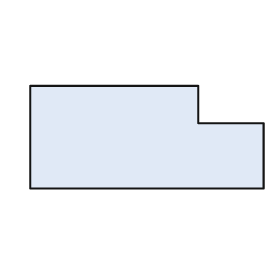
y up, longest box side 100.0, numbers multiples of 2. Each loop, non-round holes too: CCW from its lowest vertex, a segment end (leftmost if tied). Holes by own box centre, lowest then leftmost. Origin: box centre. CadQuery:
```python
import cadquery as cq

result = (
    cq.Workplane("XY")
    .moveTo(-50.0, -22.0)
    .lineTo(50.0, -22.0)
    .lineTo(50.0, 6.0)
    .lineTo(22.0, 6.0)
    .lineTo(22.0, 22.0)
    .lineTo(-50.0, 22.0)
    .close()
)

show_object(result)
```